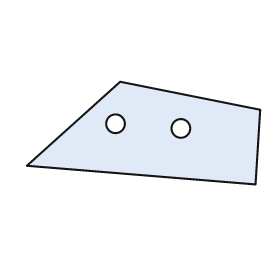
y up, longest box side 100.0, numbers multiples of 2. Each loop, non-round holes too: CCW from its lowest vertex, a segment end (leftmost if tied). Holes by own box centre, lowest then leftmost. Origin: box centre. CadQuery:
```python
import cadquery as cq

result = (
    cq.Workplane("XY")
    .moveTo(48.0, -22.0)
    .lineTo(50.0, 10.0)
    .lineTo(-10.0, 22.0)
    .lineTo(-50.0, -14.0)
    .close()
    .moveTo(16.0, 2.0)
    .circle(4.0)
    .moveTo(-12.0, 4.0)
    .circle(4.0)
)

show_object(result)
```